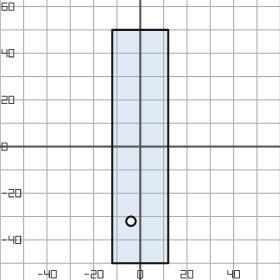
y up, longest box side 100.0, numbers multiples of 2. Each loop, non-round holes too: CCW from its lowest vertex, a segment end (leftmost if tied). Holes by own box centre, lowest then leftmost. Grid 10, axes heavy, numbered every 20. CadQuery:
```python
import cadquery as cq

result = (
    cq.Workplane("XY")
    .moveTo(-12.0, -50.0)
    .lineTo(12.0, -50.0)
    .lineTo(12.0, 50.0)
    .lineTo(-12.0, 50.0)
    .close()
    .moveTo(-4.0, -32.0)
    .circle(2.0)
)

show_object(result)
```